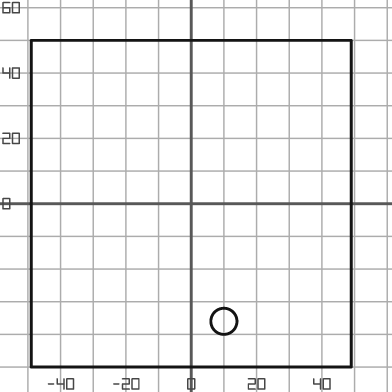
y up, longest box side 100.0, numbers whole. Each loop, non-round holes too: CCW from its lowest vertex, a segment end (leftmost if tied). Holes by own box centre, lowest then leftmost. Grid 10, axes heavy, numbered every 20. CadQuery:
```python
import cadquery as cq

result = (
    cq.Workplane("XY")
    .moveTo(-49.0, -50.0)
    .lineTo(49.0, -50.0)
    .lineTo(49.0, 50.0)
    .lineTo(-49.0, 50.0)
    .close()
    .moveTo(10.0, -36.0)
    .circle(4.0)
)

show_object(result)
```